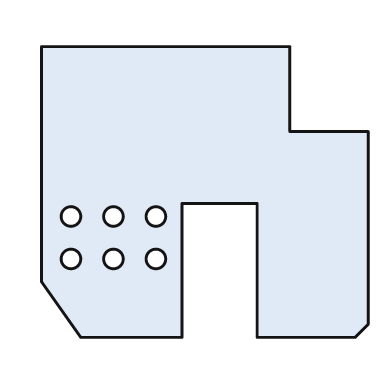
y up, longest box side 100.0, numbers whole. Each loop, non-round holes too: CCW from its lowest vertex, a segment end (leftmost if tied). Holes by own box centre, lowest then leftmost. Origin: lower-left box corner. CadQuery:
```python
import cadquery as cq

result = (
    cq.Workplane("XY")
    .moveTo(12.0, 0.0)
    .lineTo(43.0, 0.0)
    .lineTo(43.0, 41.0)
    .lineTo(66.0, 41.0)
    .lineTo(66.0, 0.0)
    .lineTo(96.0, 0.0)
    .lineTo(100.0, 4.0)
    .lineTo(100.0, 63.0)
    .lineTo(76.0, 63.0)
    .lineTo(76.0, 89.0)
    .lineTo(0.0, 89.0)
    .lineTo(0.0, 17.0)
    .close()
    .moveTo(9.0, 24.0)
    .circle(3.0)
    .moveTo(22.0, 24.0)
    .circle(3.0)
    .moveTo(35.0, 24.0)
    .circle(3.0)
    .moveTo(9.0, 37.0)
    .circle(3.0)
    .moveTo(22.0, 37.0)
    .circle(3.0)
    .moveTo(35.0, 37.0)
    .circle(3.0)
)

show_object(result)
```